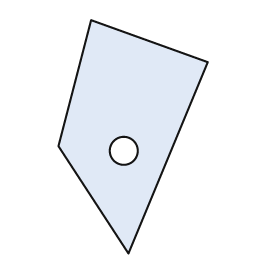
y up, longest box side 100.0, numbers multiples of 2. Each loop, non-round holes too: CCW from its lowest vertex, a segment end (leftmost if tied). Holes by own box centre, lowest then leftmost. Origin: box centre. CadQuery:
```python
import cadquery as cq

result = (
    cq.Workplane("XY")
    .moveTo(-2.0, -50.0)
    .lineTo(32.0, 32.0)
    .lineTo(-18.0, 50.0)
    .lineTo(-32.0, -4.0)
    .close()
    .moveTo(-4.0, -6.0)
    .circle(6.0)
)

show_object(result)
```